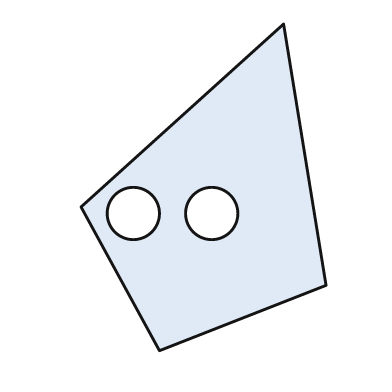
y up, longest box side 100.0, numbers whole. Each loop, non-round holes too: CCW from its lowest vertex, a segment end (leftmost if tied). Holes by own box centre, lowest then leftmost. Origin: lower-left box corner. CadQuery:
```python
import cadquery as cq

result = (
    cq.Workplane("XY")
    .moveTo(24.0, 0.0)
    .lineTo(75.0, 20.0)
    .lineTo(62.0, 100.0)
    .lineTo(0.0, 44.0)
    .close()
    .moveTo(16.0, 42.0)
    .circle(8.0)
    .moveTo(40.0, 42.0)
    .circle(8.0)
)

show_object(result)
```